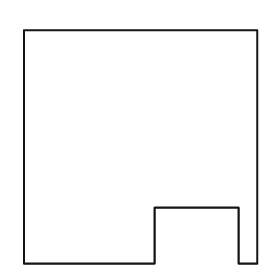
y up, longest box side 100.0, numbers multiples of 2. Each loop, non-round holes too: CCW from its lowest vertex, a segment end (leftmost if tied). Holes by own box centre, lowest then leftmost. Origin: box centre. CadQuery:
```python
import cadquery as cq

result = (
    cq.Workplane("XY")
    .moveTo(-50.0, -50.0)
    .lineTo(6.0, -50.0)
    .lineTo(6.0, -26.0)
    .lineTo(42.0, -26.0)
    .lineTo(42.0, -50.0)
    .lineTo(50.0, -50.0)
    .lineTo(50.0, 50.0)
    .lineTo(-50.0, 50.0)
    .close()
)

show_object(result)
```